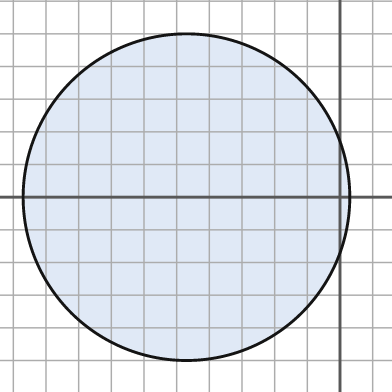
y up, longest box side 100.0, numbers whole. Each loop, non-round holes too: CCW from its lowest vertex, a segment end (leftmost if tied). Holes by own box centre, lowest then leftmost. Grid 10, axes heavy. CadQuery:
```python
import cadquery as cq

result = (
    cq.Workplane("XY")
    .moveTo(-47.0, 0.0)
    .circle(50.0)
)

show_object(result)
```